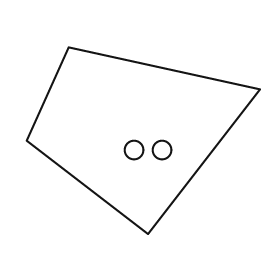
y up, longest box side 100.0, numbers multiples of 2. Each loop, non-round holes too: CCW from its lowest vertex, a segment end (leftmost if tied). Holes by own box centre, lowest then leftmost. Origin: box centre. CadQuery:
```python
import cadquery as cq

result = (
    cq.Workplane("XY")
    .moveTo(2.0, -40.0)
    .lineTo(50.0, 22.0)
    .lineTo(-32.0, 40.0)
    .lineTo(-50.0, 0.0)
    .close()
    .moveTo(-4.0, -4.0)
    .circle(4.0)
    .moveTo(8.0, -4.0)
    .circle(4.0)
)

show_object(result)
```